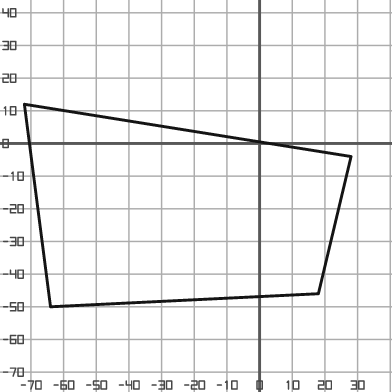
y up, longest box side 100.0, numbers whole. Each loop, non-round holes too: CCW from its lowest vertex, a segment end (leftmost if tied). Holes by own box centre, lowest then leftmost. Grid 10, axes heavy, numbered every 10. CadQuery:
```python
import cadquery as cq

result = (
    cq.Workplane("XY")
    .moveTo(-64.0, -50.0)
    .lineTo(18.0, -46.0)
    .lineTo(28.0, -4.0)
    .lineTo(-72.0, 12.0)
    .close()
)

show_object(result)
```